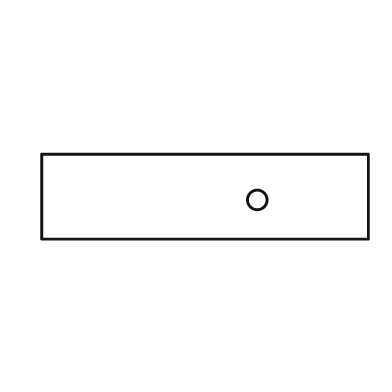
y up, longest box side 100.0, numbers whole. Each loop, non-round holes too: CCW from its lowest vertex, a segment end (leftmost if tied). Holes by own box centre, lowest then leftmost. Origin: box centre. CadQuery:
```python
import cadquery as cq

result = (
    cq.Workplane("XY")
    .moveTo(-50.0, -13.0)
    .lineTo(50.0, -13.0)
    .lineTo(50.0, 13.0)
    .lineTo(-50.0, 13.0)
    .close()
    .moveTo(16.0, -1.0)
    .circle(3.0)
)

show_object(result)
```